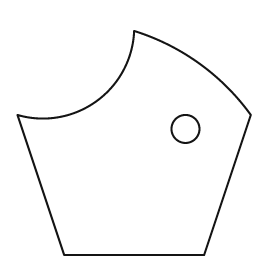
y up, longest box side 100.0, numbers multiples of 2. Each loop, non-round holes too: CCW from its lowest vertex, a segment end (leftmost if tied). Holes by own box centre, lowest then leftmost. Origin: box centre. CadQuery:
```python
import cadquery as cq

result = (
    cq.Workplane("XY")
    .moveTo(-30.0, -48.0)
    .lineTo(30.0, -48.0)
    .lineTo(50.0, 12.0)
    .threePointArc((28.0, 34.0), (0.0, 48.0))
    .threePointArc((-16.0, 18.0), (-50.0, 12.0))
    .close()
    .moveTo(22.0, 6.0)
    .circle(6.0)
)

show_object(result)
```